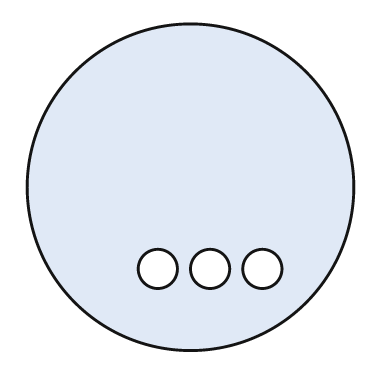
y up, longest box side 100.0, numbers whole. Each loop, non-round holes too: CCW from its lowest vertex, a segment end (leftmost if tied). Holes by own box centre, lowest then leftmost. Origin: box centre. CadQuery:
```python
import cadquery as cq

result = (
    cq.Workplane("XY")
    .moveTo(0.0, 0.0)
    .circle(50.0)
    .moveTo(-10.0, -25.0)
    .circle(6.0)
    .moveTo(6.0, -25.0)
    .circle(6.0)
    .moveTo(22.0, -25.0)
    .circle(6.0)
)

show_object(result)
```